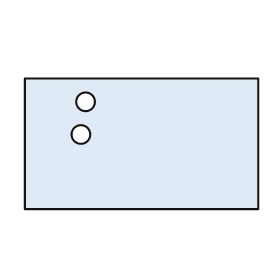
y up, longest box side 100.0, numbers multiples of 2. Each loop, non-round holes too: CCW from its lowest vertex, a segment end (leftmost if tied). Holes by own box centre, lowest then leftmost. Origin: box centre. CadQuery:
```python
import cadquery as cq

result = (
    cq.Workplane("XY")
    .moveTo(-50.0, -28.0)
    .lineTo(50.0, -28.0)
    .lineTo(50.0, 28.0)
    .lineTo(-50.0, 28.0)
    .close()
    .moveTo(-26.0, 4.0)
    .circle(4.0)
    .moveTo(-24.0, 18.0)
    .circle(4.0)
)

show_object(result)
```